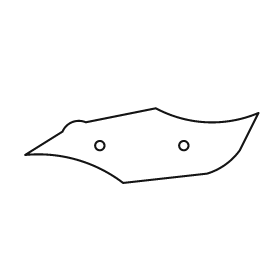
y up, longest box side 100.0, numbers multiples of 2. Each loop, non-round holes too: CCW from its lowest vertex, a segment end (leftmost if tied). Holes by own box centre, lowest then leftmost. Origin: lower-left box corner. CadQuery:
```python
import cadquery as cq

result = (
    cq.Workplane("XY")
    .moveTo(42.0, 0.0)
    .lineTo(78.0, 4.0)
    .threePointArc((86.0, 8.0), (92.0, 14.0))
    .lineTo(100.0, 30.0)
    .threePointArc((78.0, 26.0), (56.0, 32.0))
    .lineTo(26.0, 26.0)
    .threePointArc((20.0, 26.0), (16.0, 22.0))
    .lineTo(0.0, 12.0)
    .threePointArc((22.0, 10.0), (42.0, 0.0))
    .close()
    .moveTo(32.0, 16.0)
    .circle(2.0)
    .moveTo(68.0, 16.0)
    .circle(2.0)
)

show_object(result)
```